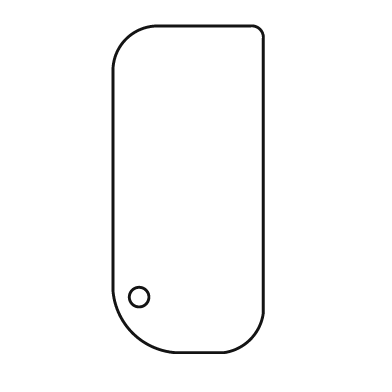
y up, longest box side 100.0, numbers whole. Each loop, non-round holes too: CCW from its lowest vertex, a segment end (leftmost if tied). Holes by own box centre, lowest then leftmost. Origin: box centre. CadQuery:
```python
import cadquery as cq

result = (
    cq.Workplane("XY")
    .moveTo(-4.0, -50.0)
    .lineTo(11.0, -50.0)
    .threePointArc((19.0, -46.0), (23.0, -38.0))
    .lineTo(23.0, 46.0)
    .threePointArc((22.0, 49.0), (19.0, 50.0))
    .lineTo(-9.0, 50.0)
    .threePointArc((-19.0, 46.0), (-23.0, 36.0))
    .lineTo(-23.0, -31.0)
    .threePointArc((-17.0, -44.0), (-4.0, -50.0))
    .close()
    .moveTo(-15.0, -33.0)
    .circle(3.0)
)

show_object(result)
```